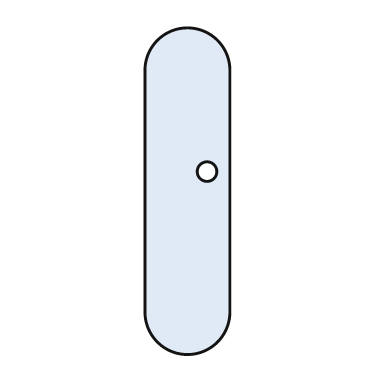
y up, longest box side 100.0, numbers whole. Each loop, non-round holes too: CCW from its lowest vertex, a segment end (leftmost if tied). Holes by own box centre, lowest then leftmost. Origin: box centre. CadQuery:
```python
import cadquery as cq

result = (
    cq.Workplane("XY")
    .moveTo(-13.0, -37.0)
    .threePointArc((0.0, -50.0), (13.0, -37.0))
    .lineTo(13.0, 37.0)
    .threePointArc((0.0, 50.0), (-13.0, 37.0))
    .close()
    .moveTo(6.0, 6.0)
    .circle(3.0)
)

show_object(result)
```